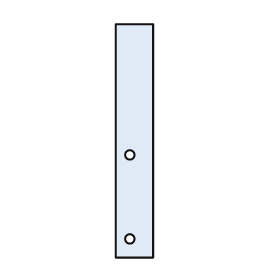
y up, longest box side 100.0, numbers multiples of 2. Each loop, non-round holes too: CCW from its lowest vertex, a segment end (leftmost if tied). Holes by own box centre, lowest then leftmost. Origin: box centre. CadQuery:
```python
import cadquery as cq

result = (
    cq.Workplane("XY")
    .moveTo(-8.0, -50.0)
    .lineTo(8.0, -50.0)
    .lineTo(8.0, 50.0)
    .lineTo(-8.0, 50.0)
    .close()
    .moveTo(-2.0, -42.0)
    .circle(2.0)
    .moveTo(-2.0, -6.0)
    .circle(2.0)
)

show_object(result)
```